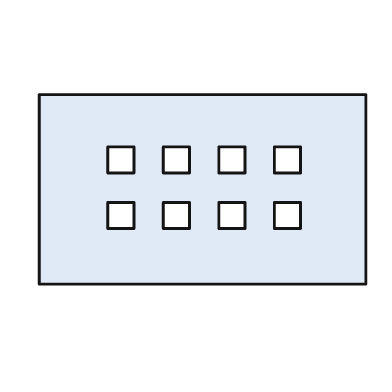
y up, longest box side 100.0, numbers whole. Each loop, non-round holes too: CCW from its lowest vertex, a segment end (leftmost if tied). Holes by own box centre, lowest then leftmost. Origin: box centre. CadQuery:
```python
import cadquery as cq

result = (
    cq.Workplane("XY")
    .moveTo(-50.0, -29.0)
    .lineTo(50.0, -29.0)
    .lineTo(50.0, 29.0)
    .lineTo(-50.0, 29.0)
    .close()
    .moveTo(-29.0, -12.0)
    .lineTo(-21.0, -12.0)
    .lineTo(-21.0, -4.0)
    .lineTo(-29.0, -4.0)
    .close()
    .moveTo(-12.0, -12.0)
    .lineTo(-4.0, -12.0)
    .lineTo(-4.0, -4.0)
    .lineTo(-12.0, -4.0)
    .close()
    .moveTo(5.0, -12.0)
    .lineTo(13.0, -12.0)
    .lineTo(13.0, -4.0)
    .lineTo(5.0, -4.0)
    .close()
    .moveTo(22.0, -12.0)
    .lineTo(30.0, -12.0)
    .lineTo(30.0, -4.0)
    .lineTo(22.0, -4.0)
    .close()
    .moveTo(-29.0, 5.0)
    .lineTo(-21.0, 5.0)
    .lineTo(-21.0, 13.0)
    .lineTo(-29.0, 13.0)
    .close()
    .moveTo(-12.0, 5.0)
    .lineTo(-4.0, 5.0)
    .lineTo(-4.0, 13.0)
    .lineTo(-12.0, 13.0)
    .close()
    .moveTo(5.0, 5.0)
    .lineTo(13.0, 5.0)
    .lineTo(13.0, 13.0)
    .lineTo(5.0, 13.0)
    .close()
    .moveTo(22.0, 5.0)
    .lineTo(30.0, 5.0)
    .lineTo(30.0, 13.0)
    .lineTo(22.0, 13.0)
    .close()
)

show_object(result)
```